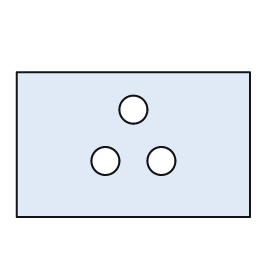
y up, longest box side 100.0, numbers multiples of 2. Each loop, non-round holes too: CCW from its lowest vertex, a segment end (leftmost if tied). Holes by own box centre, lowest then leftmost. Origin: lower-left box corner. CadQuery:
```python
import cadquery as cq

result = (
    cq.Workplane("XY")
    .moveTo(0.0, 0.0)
    .lineTo(100.0, 0.0)
    .lineTo(100.0, 62.0)
    .lineTo(0.0, 62.0)
    .close()
    .moveTo(38.0, 24.0)
    .circle(6.0)
    .moveTo(62.0, 24.0)
    .circle(6.0)
    .moveTo(50.0, 46.0)
    .circle(6.0)
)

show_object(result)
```